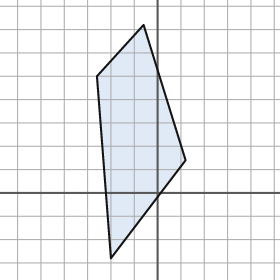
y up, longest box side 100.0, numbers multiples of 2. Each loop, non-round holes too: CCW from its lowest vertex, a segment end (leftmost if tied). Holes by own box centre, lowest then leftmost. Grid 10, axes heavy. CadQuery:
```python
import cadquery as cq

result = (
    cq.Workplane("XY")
    .moveTo(-20.0, -28.0)
    .lineTo(12.0, 14.0)
    .lineTo(-6.0, 72.0)
    .lineTo(-26.0, 50.0)
    .close()
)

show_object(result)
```